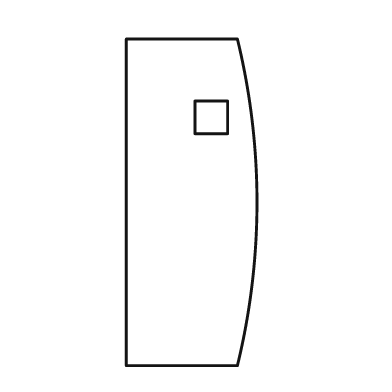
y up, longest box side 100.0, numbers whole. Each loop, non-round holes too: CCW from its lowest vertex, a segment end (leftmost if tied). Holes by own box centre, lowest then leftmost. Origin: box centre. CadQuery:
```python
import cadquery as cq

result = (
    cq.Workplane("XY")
    .moveTo(-20.0, -50.0)
    .lineTo(14.0, -50.0)
    .threePointArc((20.0, 0.0), (14.0, 50.0))
    .lineTo(-20.0, 50.0)
    .close()
    .moveTo(1.0, 21.0)
    .lineTo(11.0, 21.0)
    .lineTo(11.0, 31.0)
    .lineTo(1.0, 31.0)
    .close()
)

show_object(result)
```